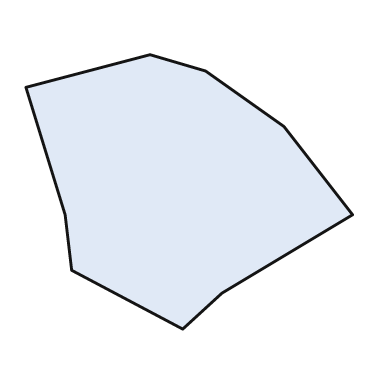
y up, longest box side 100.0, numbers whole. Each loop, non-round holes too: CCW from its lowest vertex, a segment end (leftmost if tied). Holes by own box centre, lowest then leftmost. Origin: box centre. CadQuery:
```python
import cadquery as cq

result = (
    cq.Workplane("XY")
    .moveTo(-2.0, -42.0)
    .lineTo(10.0, -31.0)
    .lineTo(50.0, -7.0)
    .lineTo(29.0, 20.0)
    .lineTo(5.0, 37.0)
    .lineTo(-12.0, 42.0)
    .lineTo(-50.0, 32.0)
    .lineTo(-38.0, -7.0)
    .lineTo(-36.0, -24.0)
    .close()
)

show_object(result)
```